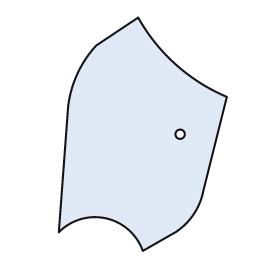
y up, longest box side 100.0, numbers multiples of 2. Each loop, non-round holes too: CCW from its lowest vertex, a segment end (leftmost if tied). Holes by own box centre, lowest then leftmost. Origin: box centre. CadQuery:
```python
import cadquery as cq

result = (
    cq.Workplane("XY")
    .moveTo(0.0, -50.0)
    .lineTo(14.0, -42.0)
    .threePointArc((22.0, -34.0), (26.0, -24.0))
    .lineTo(36.0, 16.0)
    .threePointArc((14.0, 30.0), (-2.0, 50.0))
    .lineTo(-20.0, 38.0)
    .threePointArc((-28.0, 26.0), (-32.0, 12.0))
    .lineTo(-36.0, -42.0)
    .threePointArc((-16.0, -36.0), (0.0, -50.0))
    .close()
    .moveTo(16.0, 0.0)
    .circle(2.0)
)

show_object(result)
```